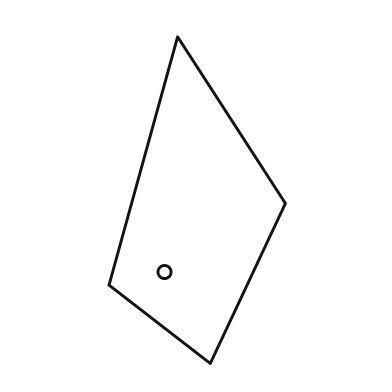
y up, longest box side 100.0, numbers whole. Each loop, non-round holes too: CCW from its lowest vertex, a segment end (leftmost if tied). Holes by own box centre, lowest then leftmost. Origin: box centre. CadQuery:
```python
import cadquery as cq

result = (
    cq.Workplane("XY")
    .moveTo(4.0, -50.0)
    .lineTo(27.0, -1.0)
    .lineTo(-6.0, 50.0)
    .lineTo(-27.0, -26.0)
    .close()
    .moveTo(-10.0, -22.0)
    .circle(2.0)
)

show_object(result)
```